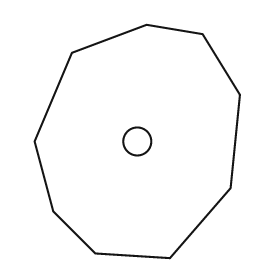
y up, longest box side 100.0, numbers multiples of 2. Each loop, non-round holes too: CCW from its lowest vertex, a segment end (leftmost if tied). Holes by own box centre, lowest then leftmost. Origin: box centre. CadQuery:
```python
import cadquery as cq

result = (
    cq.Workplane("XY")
    .moveTo(14.0, -50.0)
    .lineTo(40.0, -20.0)
    .lineTo(44.0, 20.0)
    .lineTo(28.0, 46.0)
    .lineTo(4.0, 50.0)
    .lineTo(-28.0, 38.0)
    .lineTo(-44.0, 0.0)
    .lineTo(-36.0, -30.0)
    .lineTo(-18.0, -48.0)
    .close()
    .moveTo(0.0, 0.0)
    .circle(6.0)
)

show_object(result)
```